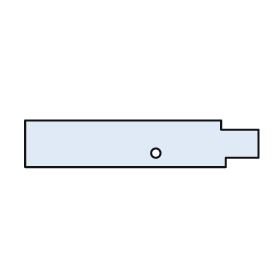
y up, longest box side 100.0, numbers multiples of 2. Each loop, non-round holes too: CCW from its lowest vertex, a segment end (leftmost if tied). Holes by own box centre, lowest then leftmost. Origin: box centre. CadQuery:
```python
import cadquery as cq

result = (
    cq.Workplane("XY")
    .moveTo(-50.0, -10.0)
    .lineTo(36.0, -10.0)
    .lineTo(36.0, -6.0)
    .lineTo(50.0, -6.0)
    .lineTo(50.0, 6.0)
    .lineTo(34.0, 6.0)
    .lineTo(34.0, 10.0)
    .lineTo(-50.0, 10.0)
    .close()
    .moveTo(6.0, -4.0)
    .circle(2.0)
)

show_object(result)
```